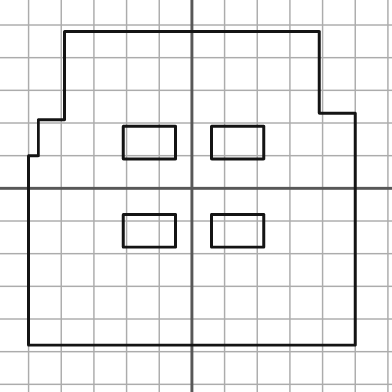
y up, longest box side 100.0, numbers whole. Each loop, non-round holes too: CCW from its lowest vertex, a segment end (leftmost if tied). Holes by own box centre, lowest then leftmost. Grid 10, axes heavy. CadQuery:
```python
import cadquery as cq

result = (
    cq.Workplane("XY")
    .moveTo(-50.0, -48.0)
    .lineTo(50.0, -48.0)
    .lineTo(50.0, 23.0)
    .lineTo(39.0, 23.0)
    .lineTo(39.0, 48.0)
    .lineTo(-39.0, 48.0)
    .lineTo(-39.0, 21.0)
    .lineTo(-47.0, 21.0)
    .lineTo(-47.0, 10.0)
    .lineTo(-50.0, 10.0)
    .close()
    .moveTo(-21.0, -18.0)
    .lineTo(-5.0, -18.0)
    .lineTo(-5.0, -8.0)
    .lineTo(-21.0, -8.0)
    .close()
    .moveTo(6.0, -18.0)
    .lineTo(22.0, -18.0)
    .lineTo(22.0, -8.0)
    .lineTo(6.0, -8.0)
    .close()
    .moveTo(-21.0, 9.0)
    .lineTo(-5.0, 9.0)
    .lineTo(-5.0, 19.0)
    .lineTo(-21.0, 19.0)
    .close()
    .moveTo(6.0, 9.0)
    .lineTo(22.0, 9.0)
    .lineTo(22.0, 19.0)
    .lineTo(6.0, 19.0)
    .close()
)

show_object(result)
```